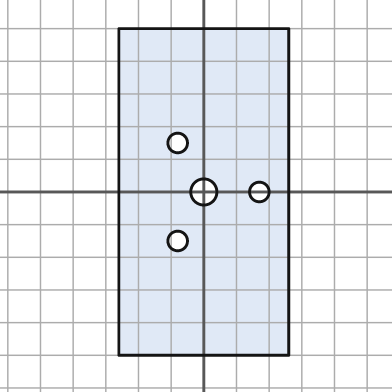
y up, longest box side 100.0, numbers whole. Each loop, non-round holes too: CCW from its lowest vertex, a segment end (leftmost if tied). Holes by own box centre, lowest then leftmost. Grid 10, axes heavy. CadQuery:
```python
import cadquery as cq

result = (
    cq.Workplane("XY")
    .moveTo(-26.0, -50.0)
    .lineTo(26.0, -50.0)
    .lineTo(26.0, 50.0)
    .lineTo(-26.0, 50.0)
    .close()
    .moveTo(-8.0, -15.0)
    .circle(3.0)
    .moveTo(0.0, 0.0)
    .circle(4.0)
    .moveTo(17.0, 0.0)
    .circle(3.0)
    .moveTo(-8.0, 15.0)
    .circle(3.0)
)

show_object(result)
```